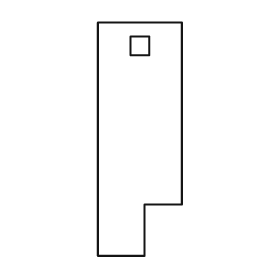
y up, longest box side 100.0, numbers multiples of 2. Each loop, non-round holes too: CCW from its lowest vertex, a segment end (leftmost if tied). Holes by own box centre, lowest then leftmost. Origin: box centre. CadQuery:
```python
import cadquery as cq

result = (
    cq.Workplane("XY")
    .moveTo(-18.0, -50.0)
    .lineTo(2.0, -50.0)
    .lineTo(2.0, -28.0)
    .lineTo(18.0, -28.0)
    .lineTo(18.0, 50.0)
    .lineTo(-18.0, 50.0)
    .close()
    .moveTo(-4.0, 36.0)
    .lineTo(4.0, 36.0)
    .lineTo(4.0, 44.0)
    .lineTo(-4.0, 44.0)
    .close()
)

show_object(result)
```